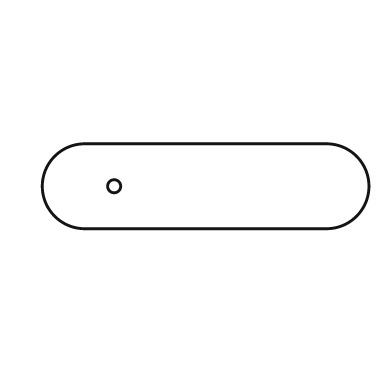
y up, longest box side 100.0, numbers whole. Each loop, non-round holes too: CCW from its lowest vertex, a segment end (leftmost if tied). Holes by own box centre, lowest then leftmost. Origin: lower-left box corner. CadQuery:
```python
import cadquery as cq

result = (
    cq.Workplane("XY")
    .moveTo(13.0, 0.0)
    .lineTo(87.0, 0.0)
    .threePointArc((100.0, 13.0), (87.0, 26.0))
    .lineTo(13.0, 26.0)
    .threePointArc((0.0, 13.0), (13.0, 0.0))
    .close()
    .moveTo(22.0, 13.0)
    .circle(2.0)
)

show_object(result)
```